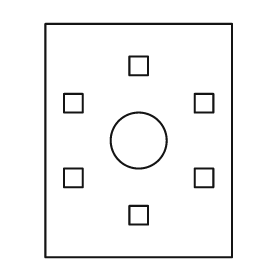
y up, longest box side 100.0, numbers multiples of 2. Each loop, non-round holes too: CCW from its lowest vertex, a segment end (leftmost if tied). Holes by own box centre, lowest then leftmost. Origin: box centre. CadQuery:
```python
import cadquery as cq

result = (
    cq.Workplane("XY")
    .moveTo(-40.0, -50.0)
    .lineTo(40.0, -50.0)
    .lineTo(40.0, 50.0)
    .lineTo(-40.0, 50.0)
    .close()
    .moveTo(-4.0, -36.0)
    .lineTo(4.0, -36.0)
    .lineTo(4.0, -28.0)
    .lineTo(-4.0, -28.0)
    .close()
    .moveTo(-32.0, -20.0)
    .lineTo(-24.0, -20.0)
    .lineTo(-24.0, -12.0)
    .lineTo(-32.0, -12.0)
    .close()
    .moveTo(24.0, -20.0)
    .lineTo(32.0, -20.0)
    .lineTo(32.0, -12.0)
    .lineTo(24.0, -12.0)
    .close()
    .moveTo(0.0, 0.0)
    .circle(12.0)
    .moveTo(-32.0, 12.0)
    .lineTo(-24.0, 12.0)
    .lineTo(-24.0, 20.0)
    .lineTo(-32.0, 20.0)
    .close()
    .moveTo(24.0, 12.0)
    .lineTo(32.0, 12.0)
    .lineTo(32.0, 20.0)
    .lineTo(24.0, 20.0)
    .close()
    .moveTo(-4.0, 28.0)
    .lineTo(4.0, 28.0)
    .lineTo(4.0, 36.0)
    .lineTo(-4.0, 36.0)
    .close()
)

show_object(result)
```